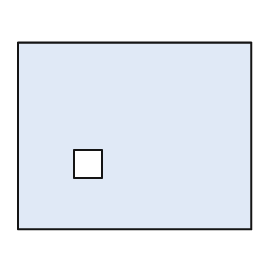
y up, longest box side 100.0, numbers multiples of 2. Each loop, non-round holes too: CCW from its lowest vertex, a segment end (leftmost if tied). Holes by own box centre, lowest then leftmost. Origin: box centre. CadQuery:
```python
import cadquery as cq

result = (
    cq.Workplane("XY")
    .moveTo(-50.0, -40.0)
    .lineTo(50.0, -40.0)
    .lineTo(50.0, 40.0)
    .lineTo(-50.0, 40.0)
    .close()
    .moveTo(-26.0, -18.0)
    .lineTo(-14.0, -18.0)
    .lineTo(-14.0, -6.0)
    .lineTo(-26.0, -6.0)
    .close()
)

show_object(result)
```